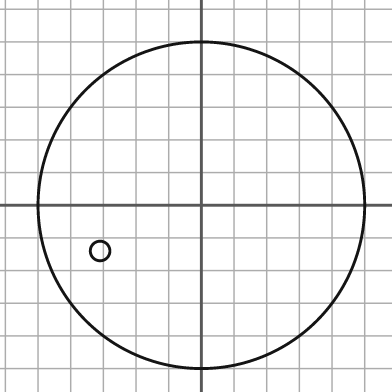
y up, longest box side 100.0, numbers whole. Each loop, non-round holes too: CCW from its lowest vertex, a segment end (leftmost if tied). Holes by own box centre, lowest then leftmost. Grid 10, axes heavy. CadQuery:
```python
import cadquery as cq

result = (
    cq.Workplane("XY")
    .moveTo(0.0, 0.0)
    .circle(50.0)
    .moveTo(-31.0, -14.0)
    .circle(3.0)
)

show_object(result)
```